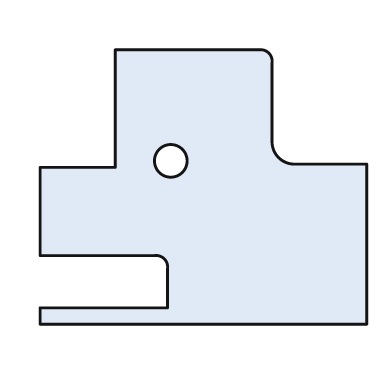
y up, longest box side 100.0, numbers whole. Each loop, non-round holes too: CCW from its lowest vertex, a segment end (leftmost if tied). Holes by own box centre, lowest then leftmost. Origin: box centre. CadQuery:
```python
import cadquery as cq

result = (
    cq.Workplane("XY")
    .moveTo(-50.0, -42.0)
    .lineTo(50.0, -42.0)
    .lineTo(50.0, 7.0)
    .lineTo(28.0, 7.0)
    .threePointArc((23.0, 9.0), (21.0, 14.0))
    .lineTo(21.0, 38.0)
    .threePointArc((20.0, 41.0), (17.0, 42.0))
    .lineTo(-27.0, 42.0)
    .lineTo(-27.0, 6.0)
    .lineTo(-50.0, 6.0)
    .lineTo(-50.0, -21.0)
    .lineTo(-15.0, -21.0)
    .threePointArc((-12.0, -22.0), (-11.0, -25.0))
    .lineTo(-11.0, -37.0)
    .lineTo(-50.0, -37.0)
    .close()
    .moveTo(-10.0, 8.0)
    .circle(5.0)
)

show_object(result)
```